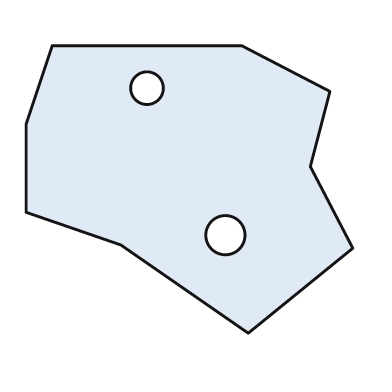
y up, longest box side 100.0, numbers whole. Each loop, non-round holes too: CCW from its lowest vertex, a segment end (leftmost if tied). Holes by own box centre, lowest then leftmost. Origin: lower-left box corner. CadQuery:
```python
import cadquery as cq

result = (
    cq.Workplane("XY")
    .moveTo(68.0, 0.0)
    .lineTo(100.0, 26.0)
    .lineTo(87.0, 51.0)
    .lineTo(93.0, 74.0)
    .lineTo(66.0, 88.0)
    .lineTo(8.0, 88.0)
    .lineTo(0.0, 64.0)
    .lineTo(0.0, 37.0)
    .lineTo(29.0, 27.0)
    .close()
    .moveTo(61.0, 30.0)
    .circle(6.0)
    .moveTo(37.0, 75.0)
    .circle(5.0)
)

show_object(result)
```